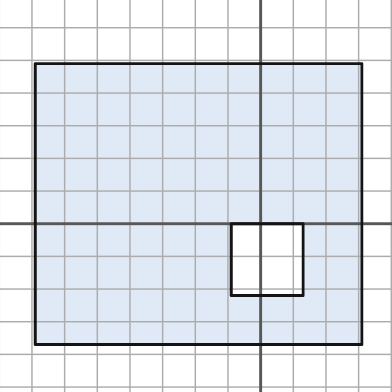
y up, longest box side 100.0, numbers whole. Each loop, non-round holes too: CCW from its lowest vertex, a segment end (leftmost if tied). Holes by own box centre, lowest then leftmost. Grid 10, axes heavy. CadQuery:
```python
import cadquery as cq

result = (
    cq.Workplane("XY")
    .moveTo(-69.0, -37.0)
    .lineTo(31.0, -37.0)
    .lineTo(31.0, 49.0)
    .lineTo(-69.0, 49.0)
    .close()
    .moveTo(-9.0, -22.0)
    .lineTo(13.0, -22.0)
    .lineTo(13.0, 0.0)
    .lineTo(-9.0, 0.0)
    .close()
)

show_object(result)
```